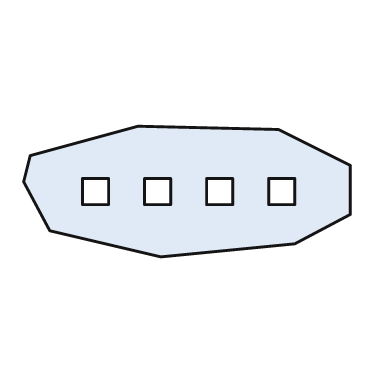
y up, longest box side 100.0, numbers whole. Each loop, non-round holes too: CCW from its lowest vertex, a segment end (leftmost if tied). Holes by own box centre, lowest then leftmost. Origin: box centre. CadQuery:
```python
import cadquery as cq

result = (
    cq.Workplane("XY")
    .moveTo(-8.0, -20.0)
    .lineTo(33.0, -16.0)
    .lineTo(50.0, -7.0)
    .lineTo(50.0, 8.0)
    .lineTo(28.0, 19.0)
    .lineTo(-15.0, 20.0)
    .lineTo(-48.0, 11.0)
    .lineTo(-50.0, 3.0)
    .lineTo(-42.0, -12.0)
    .close()
    .moveTo(-32.0, -4.0)
    .lineTo(-24.0, -4.0)
    .lineTo(-24.0, 4.0)
    .lineTo(-32.0, 4.0)
    .close()
    .moveTo(-13.0, -4.0)
    .lineTo(-5.0, -4.0)
    .lineTo(-5.0, 4.0)
    .lineTo(-13.0, 4.0)
    .close()
    .moveTo(6.0, -4.0)
    .lineTo(14.0, -4.0)
    .lineTo(14.0, 4.0)
    .lineTo(6.0, 4.0)
    .close()
    .moveTo(25.0, -4.0)
    .lineTo(33.0, -4.0)
    .lineTo(33.0, 4.0)
    .lineTo(25.0, 4.0)
    .close()
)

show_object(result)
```